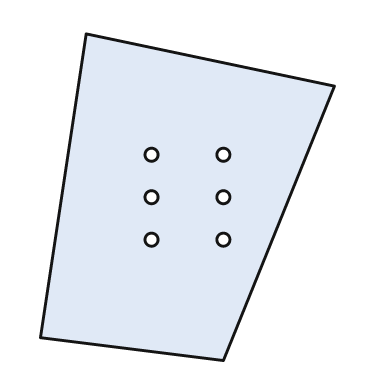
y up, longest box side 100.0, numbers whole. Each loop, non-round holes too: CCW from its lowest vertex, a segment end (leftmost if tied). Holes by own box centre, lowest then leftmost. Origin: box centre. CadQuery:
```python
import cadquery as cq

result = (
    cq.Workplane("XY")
    .moveTo(11.0, -50.0)
    .lineTo(45.0, 34.0)
    .lineTo(-31.0, 50.0)
    .lineTo(-45.0, -43.0)
    .close()
    .moveTo(-11.0, -13.0)
    .circle(2.0)
    .moveTo(11.0, -13.0)
    .circle(2.0)
    .moveTo(-11.0, 0.0)
    .circle(2.0)
    .moveTo(11.0, 0.0)
    .circle(2.0)
    .moveTo(-11.0, 13.0)
    .circle(2.0)
    .moveTo(11.0, 13.0)
    .circle(2.0)
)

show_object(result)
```